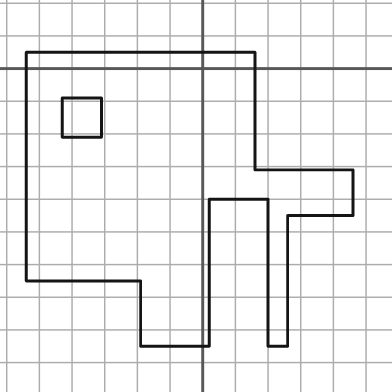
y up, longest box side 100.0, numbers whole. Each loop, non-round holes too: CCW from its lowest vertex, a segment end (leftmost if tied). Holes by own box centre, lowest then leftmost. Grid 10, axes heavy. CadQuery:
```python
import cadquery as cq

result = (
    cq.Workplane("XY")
    .moveTo(-19.0, -85.0)
    .lineTo(2.0, -85.0)
    .lineTo(2.0, -40.0)
    .lineTo(20.0, -40.0)
    .lineTo(20.0, -85.0)
    .lineTo(26.0, -85.0)
    .lineTo(26.0, -45.0)
    .lineTo(46.0, -45.0)
    .lineTo(46.0, -31.0)
    .lineTo(16.0, -31.0)
    .lineTo(16.0, 5.0)
    .lineTo(-54.0, 5.0)
    .lineTo(-54.0, -65.0)
    .lineTo(-19.0, -65.0)
    .close()
    .moveTo(-43.0, -21.0)
    .lineTo(-31.0, -21.0)
    .lineTo(-31.0, -9.0)
    .lineTo(-43.0, -9.0)
    .close()
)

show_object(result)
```